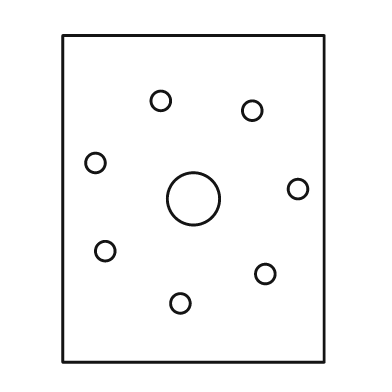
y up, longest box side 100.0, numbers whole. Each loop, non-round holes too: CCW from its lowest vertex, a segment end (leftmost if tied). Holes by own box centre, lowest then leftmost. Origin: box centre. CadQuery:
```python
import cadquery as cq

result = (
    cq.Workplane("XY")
    .moveTo(-40.0, -50.0)
    .lineTo(40.0, -50.0)
    .lineTo(40.0, 50.0)
    .lineTo(-40.0, 50.0)
    .close()
    .moveTo(-4.0, -32.0)
    .circle(3.0)
    .moveTo(22.0, -23.0)
    .circle(3.0)
    .moveTo(-27.0, -16.0)
    .circle(3.0)
    .moveTo(0.0, 0.0)
    .circle(8.0)
    .moveTo(32.0, 3.0)
    .circle(3.0)
    .moveTo(-30.0, 11.0)
    .circle(3.0)
    .moveTo(18.0, 27.0)
    .circle(3.0)
    .moveTo(-10.0, 30.0)
    .circle(3.0)
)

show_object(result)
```